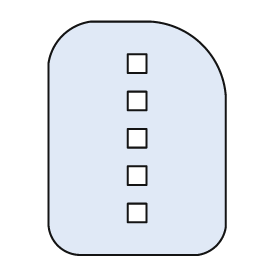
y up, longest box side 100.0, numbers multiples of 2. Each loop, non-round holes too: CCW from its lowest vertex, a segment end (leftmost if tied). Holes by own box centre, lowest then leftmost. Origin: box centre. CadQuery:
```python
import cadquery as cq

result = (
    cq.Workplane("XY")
    .moveTo(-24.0, -50.0)
    .lineTo(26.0, -50.0)
    .threePointArc((34.0, -46.0), (38.0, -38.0))
    .lineTo(38.0, 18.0)
    .threePointArc((28.0, 40.0), (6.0, 50.0))
    .lineTo(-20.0, 50.0)
    .threePointArc((-32.0, 44.0), (-38.0, 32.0))
    .lineTo(-38.0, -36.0)
    .threePointArc((-34.0, -46.0), (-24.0, -50.0))
    .close()
    .moveTo(-4.0, -36.0)
    .lineTo(4.0, -36.0)
    .lineTo(4.0, -28.0)
    .lineTo(-4.0, -28.0)
    .close()
    .moveTo(-4.0, -20.0)
    .lineTo(4.0, -20.0)
    .lineTo(4.0, -12.0)
    .lineTo(-4.0, -12.0)
    .close()
    .moveTo(-4.0, -4.0)
    .lineTo(4.0, -4.0)
    .lineTo(4.0, 4.0)
    .lineTo(-4.0, 4.0)
    .close()
    .moveTo(-4.0, 12.0)
    .lineTo(4.0, 12.0)
    .lineTo(4.0, 20.0)
    .lineTo(-4.0, 20.0)
    .close()
    .moveTo(-4.0, 28.0)
    .lineTo(4.0, 28.0)
    .lineTo(4.0, 36.0)
    .lineTo(-4.0, 36.0)
    .close()
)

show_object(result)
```